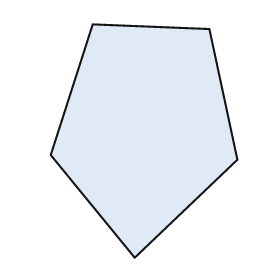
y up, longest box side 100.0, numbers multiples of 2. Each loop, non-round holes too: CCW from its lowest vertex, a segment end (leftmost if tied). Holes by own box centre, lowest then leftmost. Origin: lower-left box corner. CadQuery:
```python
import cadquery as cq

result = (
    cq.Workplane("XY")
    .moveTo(36.0, 0.0)
    .lineTo(80.0, 42.0)
    .lineTo(68.0, 98.0)
    .lineTo(18.0, 100.0)
    .lineTo(0.0, 44.0)
    .close()
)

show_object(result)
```